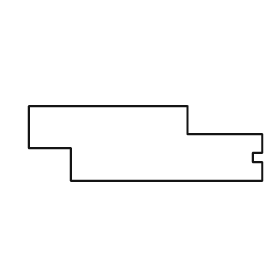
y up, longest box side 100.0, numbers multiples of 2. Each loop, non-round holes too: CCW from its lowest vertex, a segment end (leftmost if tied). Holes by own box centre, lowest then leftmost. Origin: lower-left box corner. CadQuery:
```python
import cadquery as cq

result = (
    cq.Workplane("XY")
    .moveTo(18.0, 0.0)
    .lineTo(100.0, 0.0)
    .lineTo(100.0, 8.0)
    .lineTo(96.0, 8.0)
    .lineTo(96.0, 12.0)
    .lineTo(100.0, 12.0)
    .lineTo(100.0, 20.0)
    .lineTo(68.0, 20.0)
    .lineTo(68.0, 32.0)
    .lineTo(0.0, 32.0)
    .lineTo(0.0, 14.0)
    .lineTo(18.0, 14.0)
    .close()
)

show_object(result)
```